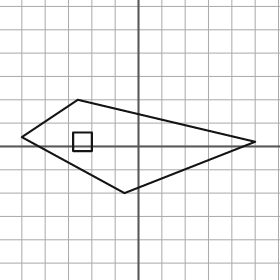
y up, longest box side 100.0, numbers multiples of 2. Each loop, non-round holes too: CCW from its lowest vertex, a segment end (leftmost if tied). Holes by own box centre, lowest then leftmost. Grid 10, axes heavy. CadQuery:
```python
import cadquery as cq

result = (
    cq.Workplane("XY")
    .moveTo(-6.0, -20.0)
    .lineTo(50.0, 2.0)
    .lineTo(-26.0, 20.0)
    .lineTo(-50.0, 4.0)
    .close()
    .moveTo(-28.0, -2.0)
    .lineTo(-20.0, -2.0)
    .lineTo(-20.0, 6.0)
    .lineTo(-28.0, 6.0)
    .close()
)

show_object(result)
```